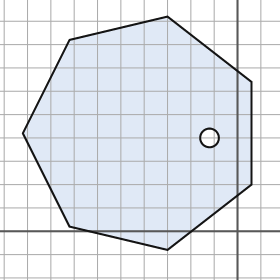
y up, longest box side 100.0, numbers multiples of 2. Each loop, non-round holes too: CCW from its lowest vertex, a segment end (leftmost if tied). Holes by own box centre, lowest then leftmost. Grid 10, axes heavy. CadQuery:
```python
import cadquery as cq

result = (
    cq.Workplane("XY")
    .moveTo(-30.0, -8.0)
    .lineTo(6.0, 20.0)
    .lineTo(6.0, 64.0)
    .lineTo(-30.0, 92.0)
    .lineTo(-72.0, 82.0)
    .lineTo(-92.0, 42.0)
    .lineTo(-72.0, 2.0)
    .close()
    .moveTo(-12.0, 40.0)
    .circle(4.0)
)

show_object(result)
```